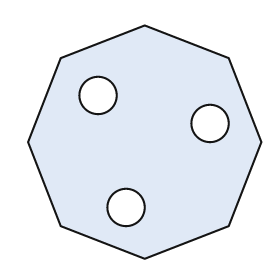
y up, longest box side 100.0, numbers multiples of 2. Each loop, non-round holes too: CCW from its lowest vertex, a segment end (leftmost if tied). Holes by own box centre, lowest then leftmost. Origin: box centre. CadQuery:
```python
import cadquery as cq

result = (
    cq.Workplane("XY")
    .moveTo(0.0, -50.0)
    .lineTo(36.0, -36.0)
    .lineTo(50.0, 0.0)
    .lineTo(36.0, 36.0)
    .lineTo(0.0, 50.0)
    .lineTo(-36.0, 36.0)
    .lineTo(-50.0, 0.0)
    .lineTo(-36.0, -36.0)
    .close()
    .moveTo(-8.0, -28.0)
    .circle(8.0)
    .moveTo(28.0, 8.0)
    .circle(8.0)
    .moveTo(-20.0, 20.0)
    .circle(8.0)
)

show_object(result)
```